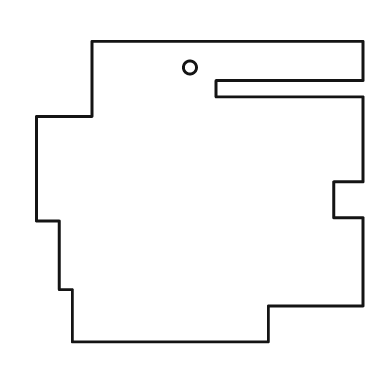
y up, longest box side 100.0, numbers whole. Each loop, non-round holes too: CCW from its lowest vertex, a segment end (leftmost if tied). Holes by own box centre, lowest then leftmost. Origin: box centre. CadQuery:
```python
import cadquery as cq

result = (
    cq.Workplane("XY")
    .moveTo(-39.0, -46.0)
    .lineTo(21.0, -46.0)
    .lineTo(21.0, -35.0)
    .lineTo(50.0, -35.0)
    .lineTo(50.0, -8.0)
    .lineTo(41.0, -8.0)
    .lineTo(41.0, 3.0)
    .lineTo(50.0, 3.0)
    .lineTo(50.0, 29.0)
    .lineTo(5.0, 29.0)
    .lineTo(5.0, 34.0)
    .lineTo(50.0, 34.0)
    .lineTo(50.0, 46.0)
    .lineTo(-33.0, 46.0)
    .lineTo(-33.0, 23.0)
    .lineTo(-50.0, 23.0)
    .lineTo(-50.0, -9.0)
    .lineTo(-43.0, -9.0)
    .lineTo(-43.0, -30.0)
    .lineTo(-39.0, -30.0)
    .close()
    .moveTo(-3.0, 38.0)
    .circle(2.0)
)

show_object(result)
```